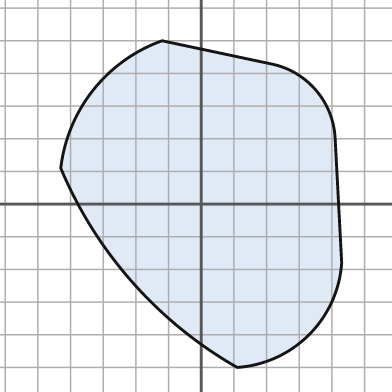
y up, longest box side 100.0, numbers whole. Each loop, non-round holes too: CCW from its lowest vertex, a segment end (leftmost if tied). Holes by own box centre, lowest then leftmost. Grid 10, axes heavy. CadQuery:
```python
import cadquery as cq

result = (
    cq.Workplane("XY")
    .moveTo(11.0, -50.0)
    .threePointArc((33.0, -40.0), (43.0, -18.0))
    .lineTo(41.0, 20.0)
    .threePointArc((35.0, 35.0), (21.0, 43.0))
    .lineTo(-12.0, 50.0)
    .threePointArc((-33.0, 35.0), (-43.0, 11.0))
    .threePointArc((-21.0, -24.0), (11.0, -50.0))
    .close()
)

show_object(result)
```